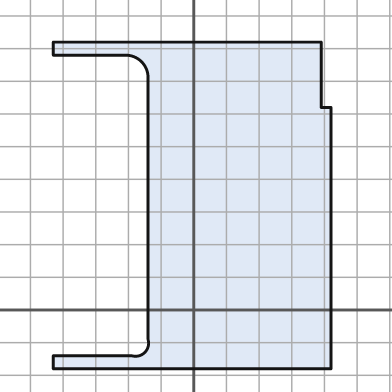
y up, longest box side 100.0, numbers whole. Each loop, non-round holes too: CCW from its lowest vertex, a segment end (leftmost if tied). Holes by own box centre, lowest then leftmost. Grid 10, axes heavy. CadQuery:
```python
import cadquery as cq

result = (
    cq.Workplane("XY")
    .moveTo(-43.0, -18.0)
    .lineTo(42.0, -18.0)
    .lineTo(42.0, 62.0)
    .lineTo(39.0, 62.0)
    .lineTo(39.0, 82.0)
    .lineTo(-43.0, 82.0)
    .lineTo(-43.0, 78.0)
    .lineTo(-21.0, 78.0)
    .threePointArc((-16.0, 76.0), (-14.0, 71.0))
    .lineTo(-14.0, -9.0)
    .threePointArc((-15.0, -13.0), (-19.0, -14.0))
    .lineTo(-43.0, -14.0)
    .close()
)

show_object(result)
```